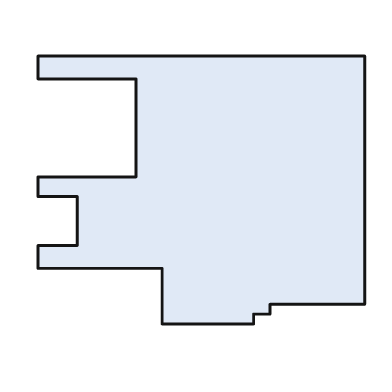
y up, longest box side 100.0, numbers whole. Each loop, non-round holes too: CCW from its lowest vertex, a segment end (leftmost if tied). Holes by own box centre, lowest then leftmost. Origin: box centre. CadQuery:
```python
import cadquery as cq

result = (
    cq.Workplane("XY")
    .moveTo(-12.0, -41.0)
    .lineTo(16.0, -41.0)
    .lineTo(16.0, -38.0)
    .lineTo(21.0, -38.0)
    .lineTo(21.0, -35.0)
    .lineTo(50.0, -35.0)
    .lineTo(50.0, 41.0)
    .lineTo(-50.0, 41.0)
    .lineTo(-50.0, 34.0)
    .lineTo(-20.0, 34.0)
    .lineTo(-20.0, 4.0)
    .lineTo(-50.0, 4.0)
    .lineTo(-50.0, -2.0)
    .lineTo(-38.0, -2.0)
    .lineTo(-38.0, -17.0)
    .lineTo(-50.0, -17.0)
    .lineTo(-50.0, -24.0)
    .lineTo(-12.0, -24.0)
    .close()
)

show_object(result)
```